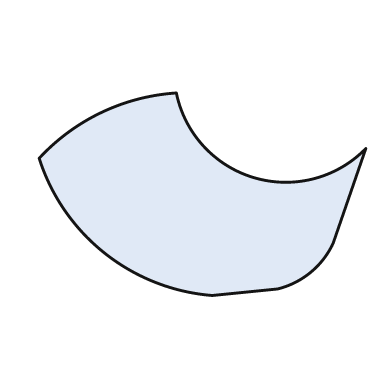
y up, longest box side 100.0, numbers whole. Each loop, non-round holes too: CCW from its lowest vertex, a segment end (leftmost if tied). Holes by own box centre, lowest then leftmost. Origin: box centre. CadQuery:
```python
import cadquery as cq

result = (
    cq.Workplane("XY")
    .moveTo(3.0, -31.0)
    .lineTo(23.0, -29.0)
    .threePointArc((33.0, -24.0), (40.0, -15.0))
    .lineTo(50.0, 14.0)
    .threePointArc((16.0, 5.0), (-8.0, 31.0))
    .threePointArc((-31.0, 25.0), (-50.0, 11.0))
    .threePointArc((-30.0, -18.0), (3.0, -31.0))
    .close()
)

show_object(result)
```